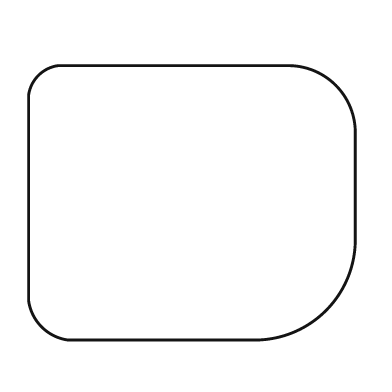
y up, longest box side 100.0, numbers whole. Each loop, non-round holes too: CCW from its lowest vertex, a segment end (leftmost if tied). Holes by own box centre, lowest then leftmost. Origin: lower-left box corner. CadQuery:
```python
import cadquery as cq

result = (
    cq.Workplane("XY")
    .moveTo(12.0, 0.0)
    .lineTo(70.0, 0.0)
    .threePointArc((91.0, 9.0), (100.0, 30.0))
    .lineTo(100.0, 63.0)
    .threePointArc((94.0, 78.0), (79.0, 84.0))
    .lineTo(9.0, 84.0)
    .threePointArc((3.0, 81.0), (0.0, 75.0))
    .lineTo(0.0, 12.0)
    .threePointArc((4.0, 4.0), (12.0, 0.0))
    .close()
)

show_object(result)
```